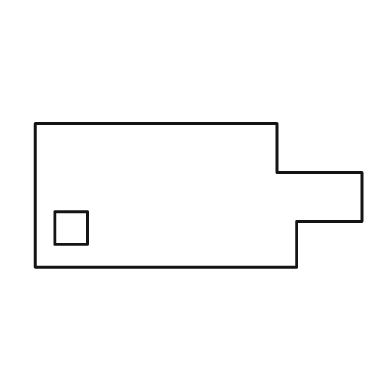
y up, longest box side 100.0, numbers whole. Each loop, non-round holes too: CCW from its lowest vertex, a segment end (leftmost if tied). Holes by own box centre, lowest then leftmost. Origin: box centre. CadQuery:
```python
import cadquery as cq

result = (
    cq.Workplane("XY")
    .moveTo(-50.0, -22.0)
    .lineTo(30.0, -22.0)
    .lineTo(30.0, -8.0)
    .lineTo(50.0, -8.0)
    .lineTo(50.0, 7.0)
    .lineTo(24.0, 7.0)
    .lineTo(24.0, 22.0)
    .lineTo(-50.0, 22.0)
    .close()
    .moveTo(-44.0, -15.0)
    .lineTo(-34.0, -15.0)
    .lineTo(-34.0, -5.0)
    .lineTo(-44.0, -5.0)
    .close()
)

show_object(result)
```